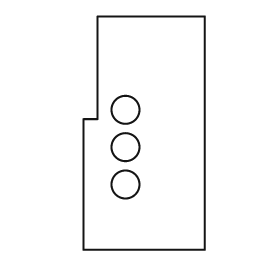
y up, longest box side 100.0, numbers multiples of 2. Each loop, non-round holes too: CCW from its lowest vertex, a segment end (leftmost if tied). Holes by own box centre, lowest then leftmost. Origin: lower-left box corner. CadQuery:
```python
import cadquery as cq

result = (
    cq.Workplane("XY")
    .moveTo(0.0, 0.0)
    .lineTo(52.0, 0.0)
    .lineTo(52.0, 100.0)
    .lineTo(6.0, 100.0)
    .lineTo(6.0, 56.0)
    .lineTo(0.0, 56.0)
    .close()
    .moveTo(18.0, 28.0)
    .circle(6.0)
    .moveTo(18.0, 44.0)
    .circle(6.0)
    .moveTo(18.0, 60.0)
    .circle(6.0)
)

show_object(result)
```